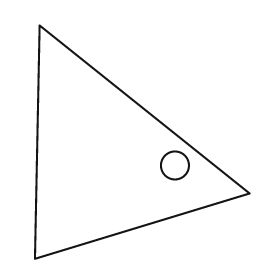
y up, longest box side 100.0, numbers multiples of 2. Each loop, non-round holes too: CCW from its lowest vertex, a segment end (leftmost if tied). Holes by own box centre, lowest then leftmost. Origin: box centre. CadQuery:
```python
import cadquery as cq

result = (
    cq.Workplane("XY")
    .moveTo(-46.0, -50.0)
    .lineTo(46.0, -22.0)
    .lineTo(-44.0, 50.0)
    .close()
    .moveTo(14.0, -10.0)
    .circle(6.0)
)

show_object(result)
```